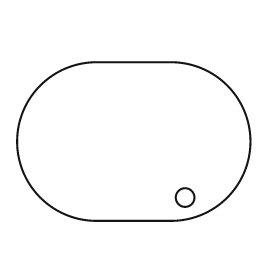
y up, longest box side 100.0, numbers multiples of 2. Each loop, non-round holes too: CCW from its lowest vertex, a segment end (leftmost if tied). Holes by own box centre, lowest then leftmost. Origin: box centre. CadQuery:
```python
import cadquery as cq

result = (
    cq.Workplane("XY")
    .moveTo(-16.0, -34.0)
    .lineTo(16.0, -34.0)
    .threePointArc((50.0, 0.0), (16.0, 34.0))
    .lineTo(-16.0, 34.0)
    .threePointArc((-50.0, 0.0), (-16.0, -34.0))
    .close()
    .moveTo(22.0, -24.0)
    .circle(4.0)
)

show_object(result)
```